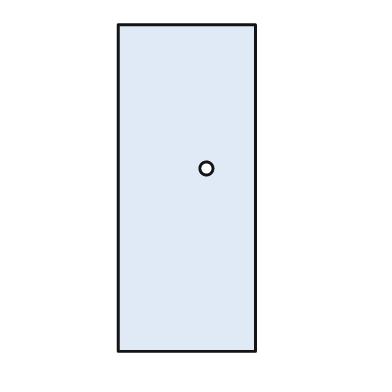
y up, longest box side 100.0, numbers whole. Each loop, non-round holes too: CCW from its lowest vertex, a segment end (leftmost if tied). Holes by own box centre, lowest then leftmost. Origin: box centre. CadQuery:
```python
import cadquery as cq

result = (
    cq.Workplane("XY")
    .moveTo(-21.0, -50.0)
    .lineTo(21.0, -50.0)
    .lineTo(21.0, 50.0)
    .lineTo(-21.0, 50.0)
    .close()
    .moveTo(6.0, 6.0)
    .circle(2.0)
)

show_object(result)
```